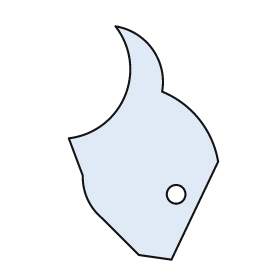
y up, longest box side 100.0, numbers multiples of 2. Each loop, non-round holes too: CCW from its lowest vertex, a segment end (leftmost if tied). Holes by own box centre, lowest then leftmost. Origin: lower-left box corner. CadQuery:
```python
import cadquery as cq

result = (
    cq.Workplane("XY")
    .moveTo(44.0, 0.0)
    .lineTo(64.0, 42.0)
    .threePointArc((56.0, 60.0), (40.0, 72.0))
    .threePointArc((36.0, 90.0), (20.0, 100.0))
    .threePointArc((24.0, 70.0), (0.0, 52.0))
    .lineTo(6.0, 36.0)
    .threePointArc((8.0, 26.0), (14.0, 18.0))
    .lineTo(30.0, 2.0)
    .close()
    .moveTo(46.0, 28.0)
    .circle(4.0)
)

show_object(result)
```